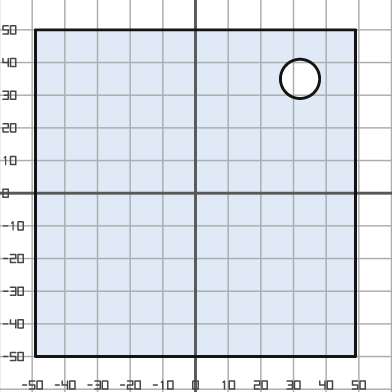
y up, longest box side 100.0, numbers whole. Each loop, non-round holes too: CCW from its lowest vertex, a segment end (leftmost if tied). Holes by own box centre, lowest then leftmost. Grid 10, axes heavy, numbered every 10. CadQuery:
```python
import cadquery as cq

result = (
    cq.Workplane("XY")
    .moveTo(-49.0, -50.0)
    .lineTo(49.0, -50.0)
    .lineTo(49.0, 50.0)
    .lineTo(-49.0, 50.0)
    .close()
    .moveTo(32.0, 35.0)
    .circle(6.0)
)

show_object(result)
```